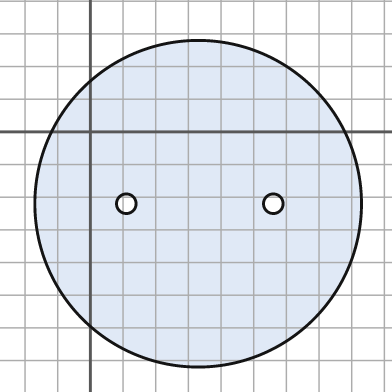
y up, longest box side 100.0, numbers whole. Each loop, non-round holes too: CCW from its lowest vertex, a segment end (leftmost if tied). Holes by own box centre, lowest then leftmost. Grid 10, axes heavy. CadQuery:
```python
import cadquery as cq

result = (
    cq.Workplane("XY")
    .moveTo(33.0, -22.0)
    .circle(50.0)
    .moveTo(11.0, -22.0)
    .circle(3.0)
    .moveTo(56.0, -22.0)
    .circle(3.0)
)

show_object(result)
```